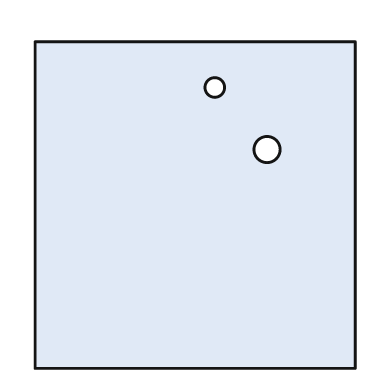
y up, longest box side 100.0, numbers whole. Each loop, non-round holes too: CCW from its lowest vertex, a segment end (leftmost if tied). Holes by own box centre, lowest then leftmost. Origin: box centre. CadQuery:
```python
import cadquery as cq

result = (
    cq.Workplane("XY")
    .moveTo(-49.0, -50.0)
    .lineTo(49.0, -50.0)
    .lineTo(49.0, 50.0)
    .lineTo(-49.0, 50.0)
    .close()
    .moveTo(22.0, 17.0)
    .circle(4.0)
    .moveTo(6.0, 36.0)
    .circle(3.0)
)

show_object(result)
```